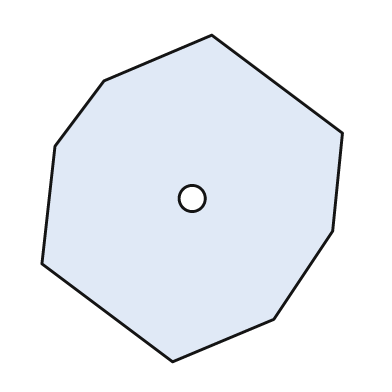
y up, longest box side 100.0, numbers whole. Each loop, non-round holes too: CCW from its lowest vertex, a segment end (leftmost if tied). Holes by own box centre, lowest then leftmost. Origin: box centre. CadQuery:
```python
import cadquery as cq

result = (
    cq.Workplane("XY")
    .moveTo(-6.0, -50.0)
    .lineTo(25.0, -37.0)
    .lineTo(43.0, -10.0)
    .lineTo(46.0, 20.0)
    .lineTo(6.0, 50.0)
    .lineTo(-27.0, 36.0)
    .lineTo(-42.0, 16.0)
    .lineTo(-46.0, -20.0)
    .close()
    .moveTo(0.0, 0.0)
    .circle(4.0)
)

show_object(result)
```